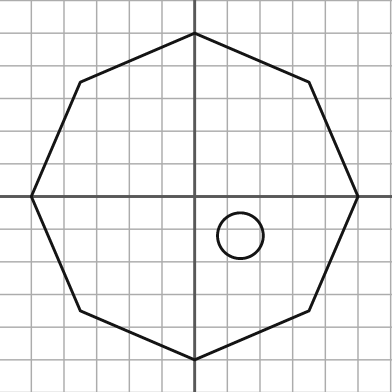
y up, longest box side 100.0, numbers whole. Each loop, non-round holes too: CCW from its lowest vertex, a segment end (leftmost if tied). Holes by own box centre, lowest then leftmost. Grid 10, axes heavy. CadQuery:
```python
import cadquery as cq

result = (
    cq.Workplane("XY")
    .moveTo(0.0, -50.0)
    .lineTo(35.0, -35.0)
    .lineTo(50.0, 0.0)
    .lineTo(35.0, 35.0)
    .lineTo(0.0, 50.0)
    .lineTo(-35.0, 35.0)
    .lineTo(-50.0, 0.0)
    .lineTo(-35.0, -35.0)
    .close()
    .moveTo(14.0, -12.0)
    .circle(7.0)
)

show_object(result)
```